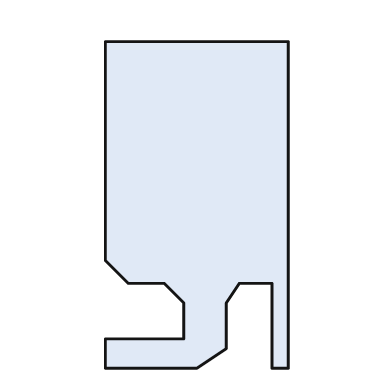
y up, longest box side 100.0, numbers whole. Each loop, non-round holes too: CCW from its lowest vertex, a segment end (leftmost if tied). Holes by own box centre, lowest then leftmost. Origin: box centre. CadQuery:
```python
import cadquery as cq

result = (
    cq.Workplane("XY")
    .moveTo(-28.0, -50.0)
    .lineTo(0.0, -50.0)
    .lineTo(9.0, -44.0)
    .lineTo(9.0, -30.0)
    .lineTo(13.0, -24.0)
    .lineTo(23.0, -24.0)
    .lineTo(23.0, -50.0)
    .lineTo(28.0, -50.0)
    .lineTo(28.0, 50.0)
    .lineTo(-28.0, 50.0)
    .lineTo(-28.0, -17.0)
    .lineTo(-21.0, -24.0)
    .lineTo(-10.0, -24.0)
    .lineTo(-4.0, -30.0)
    .lineTo(-4.0, -41.0)
    .lineTo(-28.0, -41.0)
    .close()
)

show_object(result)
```